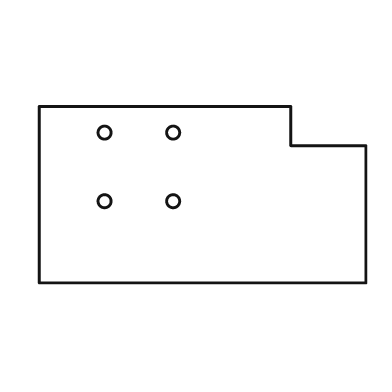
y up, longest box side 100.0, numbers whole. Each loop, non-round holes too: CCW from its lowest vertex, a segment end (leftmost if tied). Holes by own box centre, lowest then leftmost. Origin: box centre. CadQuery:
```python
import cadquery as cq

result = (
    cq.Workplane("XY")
    .moveTo(-50.0, -27.0)
    .lineTo(50.0, -27.0)
    .lineTo(50.0, 15.0)
    .lineTo(27.0, 15.0)
    .lineTo(27.0, 27.0)
    .lineTo(-50.0, 27.0)
    .close()
    .moveTo(-30.0, -2.0)
    .circle(2.0)
    .moveTo(-9.0, -2.0)
    .circle(2.0)
    .moveTo(-30.0, 19.0)
    .circle(2.0)
    .moveTo(-9.0, 19.0)
    .circle(2.0)
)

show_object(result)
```